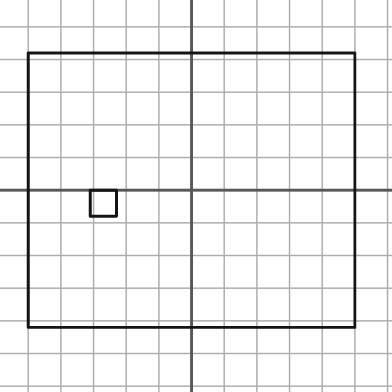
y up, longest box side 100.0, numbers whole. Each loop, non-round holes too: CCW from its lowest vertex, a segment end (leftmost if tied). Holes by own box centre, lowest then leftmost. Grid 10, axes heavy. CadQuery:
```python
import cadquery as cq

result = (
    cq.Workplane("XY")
    .moveTo(-50.0, -42.0)
    .lineTo(50.0, -42.0)
    .lineTo(50.0, 42.0)
    .lineTo(-50.0, 42.0)
    .close()
    .moveTo(-31.0, -8.0)
    .lineTo(-23.0, -8.0)
    .lineTo(-23.0, 0.0)
    .lineTo(-31.0, 0.0)
    .close()
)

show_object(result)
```